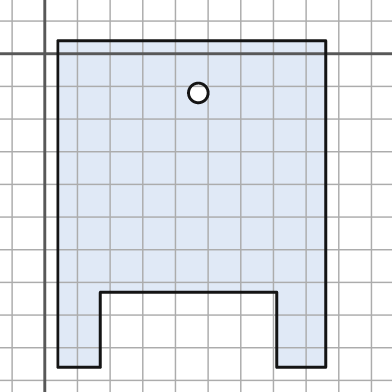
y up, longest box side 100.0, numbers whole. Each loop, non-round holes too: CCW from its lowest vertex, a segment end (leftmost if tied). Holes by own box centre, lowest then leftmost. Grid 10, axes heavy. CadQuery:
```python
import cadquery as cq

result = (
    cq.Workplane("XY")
    .moveTo(4.0, -96.0)
    .lineTo(17.0, -96.0)
    .lineTo(17.0, -73.0)
    .lineTo(71.0, -73.0)
    .lineTo(71.0, -96.0)
    .lineTo(86.0, -96.0)
    .lineTo(86.0, 4.0)
    .lineTo(4.0, 4.0)
    .close()
    .moveTo(47.0, -12.0)
    .circle(3.0)
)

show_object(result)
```